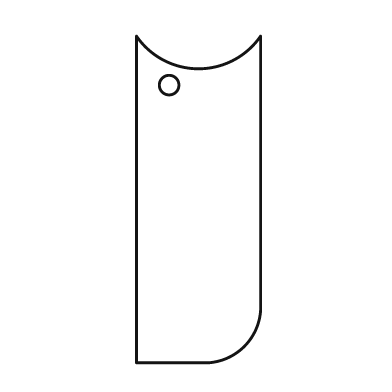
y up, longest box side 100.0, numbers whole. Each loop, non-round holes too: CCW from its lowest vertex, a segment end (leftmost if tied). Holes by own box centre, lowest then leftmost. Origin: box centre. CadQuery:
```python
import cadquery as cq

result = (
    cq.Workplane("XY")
    .moveTo(-19.0, -50.0)
    .lineTo(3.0, -50.0)
    .threePointArc((14.0, -45.0), (19.0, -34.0))
    .lineTo(19.0, 50.0)
    .threePointArc((0.0, 40.0), (-19.0, 50.0))
    .close()
    .moveTo(-9.0, 35.0)
    .circle(3.0)
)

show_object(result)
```